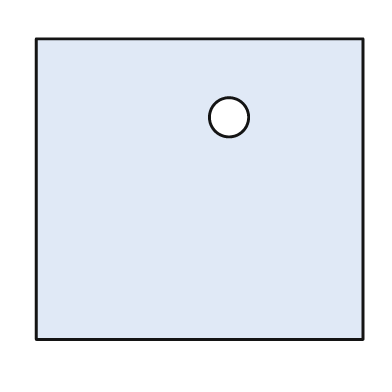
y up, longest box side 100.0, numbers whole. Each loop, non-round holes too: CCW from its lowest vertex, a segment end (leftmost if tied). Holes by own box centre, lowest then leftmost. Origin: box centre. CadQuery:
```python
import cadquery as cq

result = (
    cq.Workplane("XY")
    .moveTo(-50.0, -46.0)
    .lineTo(50.0, -46.0)
    .lineTo(50.0, 46.0)
    .lineTo(-50.0, 46.0)
    .close()
    .moveTo(9.0, 22.0)
    .circle(6.0)
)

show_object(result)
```